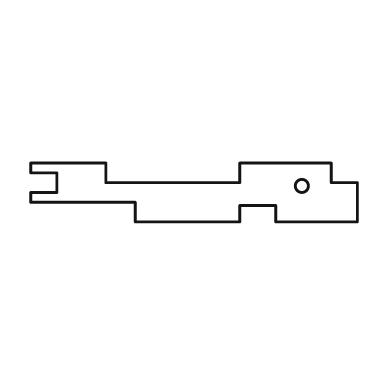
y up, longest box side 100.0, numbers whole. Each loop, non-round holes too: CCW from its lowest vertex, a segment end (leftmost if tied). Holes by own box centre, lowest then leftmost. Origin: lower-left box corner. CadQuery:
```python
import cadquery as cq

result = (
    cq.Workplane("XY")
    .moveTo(32.0, 0.0)
    .lineTo(64.0, 0.0)
    .lineTo(64.0, 5.0)
    .lineTo(75.0, 5.0)
    .lineTo(75.0, 0.0)
    .lineTo(100.0, 0.0)
    .lineTo(100.0, 12.0)
    .lineTo(92.0, 12.0)
    .lineTo(92.0, 18.0)
    .lineTo(64.0, 18.0)
    .lineTo(64.0, 12.0)
    .lineTo(23.0, 12.0)
    .lineTo(23.0, 18.0)
    .lineTo(0.0, 18.0)
    .lineTo(0.0, 15.0)
    .lineTo(8.0, 15.0)
    .lineTo(8.0, 9.0)
    .lineTo(0.0, 9.0)
    .lineTo(0.0, 6.0)
    .lineTo(32.0, 6.0)
    .close()
    .moveTo(83.0, 11.0)
    .circle(2.0)
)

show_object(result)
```